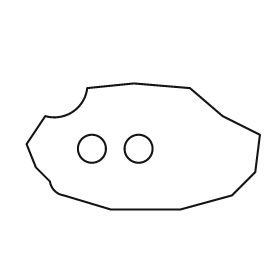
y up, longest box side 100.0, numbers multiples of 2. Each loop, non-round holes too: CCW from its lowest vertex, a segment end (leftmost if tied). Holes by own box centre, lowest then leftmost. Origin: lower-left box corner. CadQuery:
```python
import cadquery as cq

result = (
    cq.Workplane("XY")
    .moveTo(36.0, 0.0)
    .lineTo(66.0, 0.0)
    .lineTo(88.0, 6.0)
    .lineTo(98.0, 16.0)
    .lineTo(100.0, 32.0)
    .lineTo(84.0, 40.0)
    .lineTo(70.0, 52.0)
    .lineTo(46.0, 54.0)
    .lineTo(26.0, 52.0)
    .threePointArc((20.0, 42.0), (8.0, 40.0))
    .lineTo(0.0, 28.0)
    .lineTo(4.0, 18.0)
    .lineTo(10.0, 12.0)
    .threePointArc((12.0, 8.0), (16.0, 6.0))
    .close()
    .moveTo(28.0, 26.0)
    .circle(6.0)
    .moveTo(48.0, 26.0)
    .circle(6.0)
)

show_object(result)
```